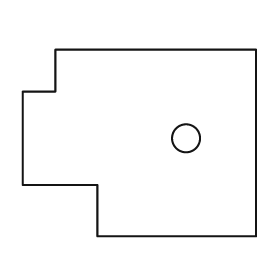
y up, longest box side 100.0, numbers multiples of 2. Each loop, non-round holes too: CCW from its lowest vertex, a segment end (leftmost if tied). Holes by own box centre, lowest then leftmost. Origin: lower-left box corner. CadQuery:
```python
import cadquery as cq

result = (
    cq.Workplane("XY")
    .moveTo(32.0, 0.0)
    .lineTo(100.0, 0.0)
    .lineTo(100.0, 80.0)
    .lineTo(14.0, 80.0)
    .lineTo(14.0, 62.0)
    .lineTo(0.0, 62.0)
    .lineTo(0.0, 22.0)
    .lineTo(32.0, 22.0)
    .close()
    .moveTo(70.0, 42.0)
    .circle(6.0)
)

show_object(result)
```